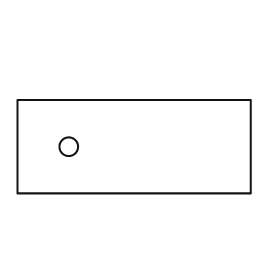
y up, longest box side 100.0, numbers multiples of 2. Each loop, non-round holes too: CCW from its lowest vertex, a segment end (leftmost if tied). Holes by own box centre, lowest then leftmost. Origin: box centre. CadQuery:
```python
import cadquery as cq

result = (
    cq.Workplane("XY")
    .moveTo(-50.0, -20.0)
    .lineTo(50.0, -20.0)
    .lineTo(50.0, 20.0)
    .lineTo(-50.0, 20.0)
    .close()
    .moveTo(-28.0, 0.0)
    .circle(4.0)
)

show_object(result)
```